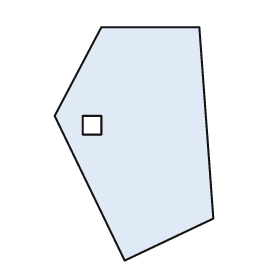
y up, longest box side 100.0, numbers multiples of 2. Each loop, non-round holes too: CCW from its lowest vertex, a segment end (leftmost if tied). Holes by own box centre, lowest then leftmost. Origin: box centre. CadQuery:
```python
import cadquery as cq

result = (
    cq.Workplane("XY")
    .moveTo(-4.0, -50.0)
    .lineTo(34.0, -32.0)
    .lineTo(28.0, 50.0)
    .lineTo(-14.0, 50.0)
    .lineTo(-34.0, 12.0)
    .close()
    .moveTo(-22.0, 4.0)
    .lineTo(-14.0, 4.0)
    .lineTo(-14.0, 12.0)
    .lineTo(-22.0, 12.0)
    .close()
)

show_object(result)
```